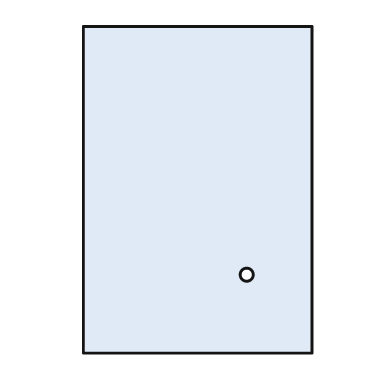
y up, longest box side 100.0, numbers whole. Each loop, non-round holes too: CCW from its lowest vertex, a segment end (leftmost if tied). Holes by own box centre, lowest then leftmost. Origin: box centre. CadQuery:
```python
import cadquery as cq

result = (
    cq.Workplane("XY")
    .moveTo(-35.0, -50.0)
    .lineTo(35.0, -50.0)
    .lineTo(35.0, 50.0)
    .lineTo(-35.0, 50.0)
    .close()
    .moveTo(15.0, -26.0)
    .circle(2.0)
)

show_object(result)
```